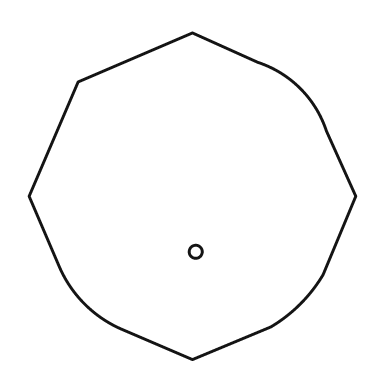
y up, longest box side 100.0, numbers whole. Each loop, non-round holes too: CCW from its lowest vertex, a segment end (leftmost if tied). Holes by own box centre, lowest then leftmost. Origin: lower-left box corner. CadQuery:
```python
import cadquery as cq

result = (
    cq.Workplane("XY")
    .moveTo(50.0, 0.0)
    .lineTo(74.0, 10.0)
    .threePointArc((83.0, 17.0), (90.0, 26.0))
    .lineTo(100.0, 50.0)
    .lineTo(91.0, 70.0)
    .threePointArc((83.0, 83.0), (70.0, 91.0))
    .lineTo(50.0, 100.0)
    .lineTo(15.0, 85.0)
    .lineTo(0.0, 50.0)
    .lineTo(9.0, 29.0)
    .threePointArc((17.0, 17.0), (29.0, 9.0))
    .close()
    .moveTo(51.0, 33.0)
    .circle(2.0)
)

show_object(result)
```